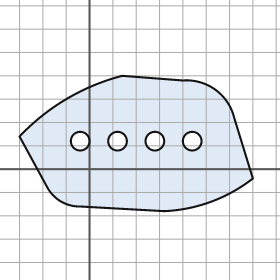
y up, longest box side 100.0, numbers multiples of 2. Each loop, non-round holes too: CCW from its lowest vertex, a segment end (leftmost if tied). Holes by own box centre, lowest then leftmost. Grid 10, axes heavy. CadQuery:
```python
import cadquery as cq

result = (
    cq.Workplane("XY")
    .moveTo(32.0, -18.0)
    .threePointArc((52.0, -14.0), (70.0, -4.0))
    .lineTo(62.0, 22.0)
    .threePointArc((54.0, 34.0), (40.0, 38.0))
    .lineTo(14.0, 40.0)
    .threePointArc((-10.0, 30.0), (-30.0, 14.0))
    .lineTo(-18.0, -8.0)
    .threePointArc((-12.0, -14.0), (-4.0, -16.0))
    .close()
    .moveTo(-4.0, 12.0)
    .circle(4.0)
    .moveTo(12.0, 12.0)
    .circle(4.0)
    .moveTo(28.0, 12.0)
    .circle(4.0)
    .moveTo(44.0, 12.0)
    .circle(4.0)
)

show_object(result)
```